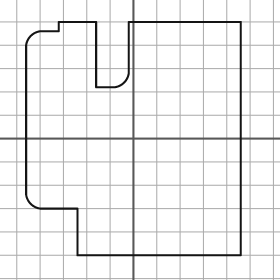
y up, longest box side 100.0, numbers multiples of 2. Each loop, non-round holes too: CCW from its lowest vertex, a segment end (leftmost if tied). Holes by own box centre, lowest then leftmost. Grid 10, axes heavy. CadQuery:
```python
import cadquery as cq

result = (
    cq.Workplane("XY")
    .moveTo(-24.0, -50.0)
    .lineTo(46.0, -50.0)
    .lineTo(46.0, 50.0)
    .lineTo(-2.0, 50.0)
    .lineTo(-2.0, 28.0)
    .threePointArc((-4.0, 24.0), (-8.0, 22.0))
    .lineTo(-16.0, 22.0)
    .lineTo(-16.0, 50.0)
    .lineTo(-32.0, 50.0)
    .lineTo(-32.0, 46.0)
    .lineTo(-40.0, 46.0)
    .threePointArc((-44.0, 44.0), (-46.0, 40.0))
    .lineTo(-46.0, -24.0)
    .threePointArc((-44.0, -28.0), (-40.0, -30.0))
    .lineTo(-24.0, -30.0)
    .close()
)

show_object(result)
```